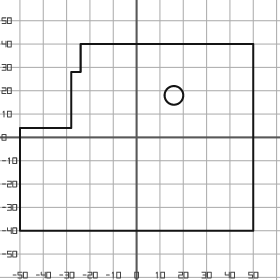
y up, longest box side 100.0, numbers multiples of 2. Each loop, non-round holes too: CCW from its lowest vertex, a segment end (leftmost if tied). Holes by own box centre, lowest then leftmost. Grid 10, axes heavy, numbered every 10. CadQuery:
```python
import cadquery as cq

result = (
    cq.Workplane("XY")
    .moveTo(-50.0, -40.0)
    .lineTo(50.0, -40.0)
    .lineTo(50.0, 40.0)
    .lineTo(-24.0, 40.0)
    .lineTo(-24.0, 28.0)
    .lineTo(-28.0, 28.0)
    .lineTo(-28.0, 4.0)
    .lineTo(-50.0, 4.0)
    .close()
    .moveTo(16.0, 18.0)
    .circle(4.0)
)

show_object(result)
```